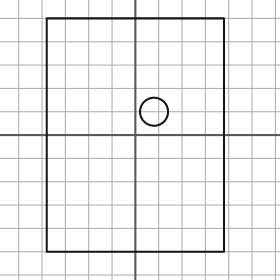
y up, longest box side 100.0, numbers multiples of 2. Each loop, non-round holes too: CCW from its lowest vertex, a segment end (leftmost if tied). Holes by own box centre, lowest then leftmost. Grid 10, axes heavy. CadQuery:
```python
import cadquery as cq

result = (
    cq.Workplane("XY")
    .moveTo(-38.0, -50.0)
    .lineTo(38.0, -50.0)
    .lineTo(38.0, 50.0)
    .lineTo(-38.0, 50.0)
    .close()
    .moveTo(8.0, 10.0)
    .circle(6.0)
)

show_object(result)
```